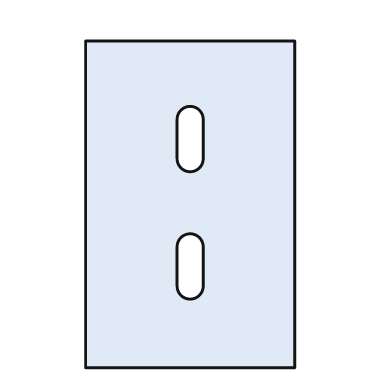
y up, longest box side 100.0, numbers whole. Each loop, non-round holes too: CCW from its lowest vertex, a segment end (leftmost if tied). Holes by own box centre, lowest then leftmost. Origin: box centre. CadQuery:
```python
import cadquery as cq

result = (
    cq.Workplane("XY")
    .moveTo(-32.0, -50.0)
    .lineTo(32.0, -50.0)
    .lineTo(32.0, 50.0)
    .lineTo(-32.0, 50.0)
    .close()
    .moveTo(-4.0, -25.0)
    .threePointArc((0.0, -29.0), (4.0, -25.0))
    .lineTo(4.0, -13.0)
    .threePointArc((0.0, -9.0), (-4.0, -13.0))
    .close()
    .moveTo(-4.0, 14.0)
    .threePointArc((0.0, 10.0), (4.0, 14.0))
    .lineTo(4.0, 26.0)
    .threePointArc((0.0, 30.0), (-4.0, 26.0))
    .close()
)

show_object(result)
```